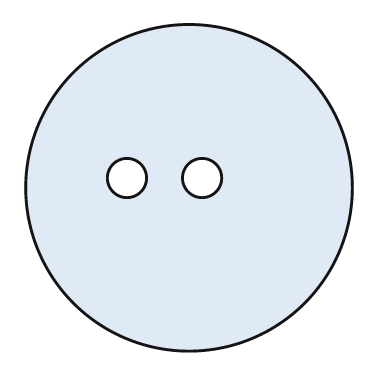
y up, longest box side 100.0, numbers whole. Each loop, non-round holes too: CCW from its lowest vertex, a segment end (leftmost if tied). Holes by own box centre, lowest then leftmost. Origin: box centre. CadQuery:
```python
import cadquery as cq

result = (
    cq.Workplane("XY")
    .moveTo(0.0, 0.0)
    .circle(50.0)
    .moveTo(-19.0, 3.0)
    .circle(6.0)
    .moveTo(4.0, 3.0)
    .circle(6.0)
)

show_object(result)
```